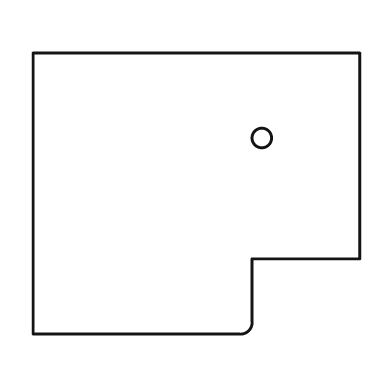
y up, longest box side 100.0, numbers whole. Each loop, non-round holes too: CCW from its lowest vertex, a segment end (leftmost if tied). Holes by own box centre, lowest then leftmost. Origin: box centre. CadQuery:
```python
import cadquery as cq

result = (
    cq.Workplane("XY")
    .moveTo(-50.0, -43.0)
    .lineTo(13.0, -43.0)
    .threePointArc((16.0, -42.0), (17.0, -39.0))
    .lineTo(17.0, -20.0)
    .lineTo(50.0, -20.0)
    .lineTo(50.0, 43.0)
    .lineTo(-50.0, 43.0)
    .close()
    .moveTo(20.0, 17.0)
    .circle(3.0)
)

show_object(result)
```